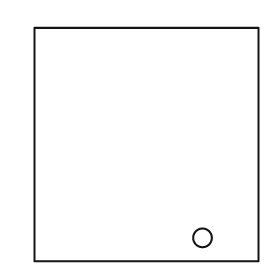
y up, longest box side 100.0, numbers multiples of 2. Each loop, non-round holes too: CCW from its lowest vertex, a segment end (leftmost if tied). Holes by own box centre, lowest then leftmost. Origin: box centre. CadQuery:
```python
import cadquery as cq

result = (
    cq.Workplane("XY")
    .moveTo(-48.0, -50.0)
    .lineTo(48.0, -50.0)
    .lineTo(48.0, 50.0)
    .lineTo(-48.0, 50.0)
    .close()
    .moveTo(24.0, -40.0)
    .circle(4.0)
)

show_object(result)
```